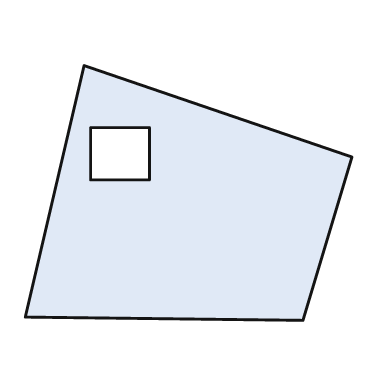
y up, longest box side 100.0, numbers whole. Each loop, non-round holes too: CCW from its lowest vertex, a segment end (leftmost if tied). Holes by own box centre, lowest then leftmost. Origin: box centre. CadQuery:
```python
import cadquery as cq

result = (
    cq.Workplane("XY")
    .moveTo(35.0, -39.0)
    .lineTo(50.0, 11.0)
    .lineTo(-32.0, 39.0)
    .lineTo(-50.0, -38.0)
    .close()
    .moveTo(-30.0, 4.0)
    .lineTo(-12.0, 4.0)
    .lineTo(-12.0, 20.0)
    .lineTo(-30.0, 20.0)
    .close()
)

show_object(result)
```